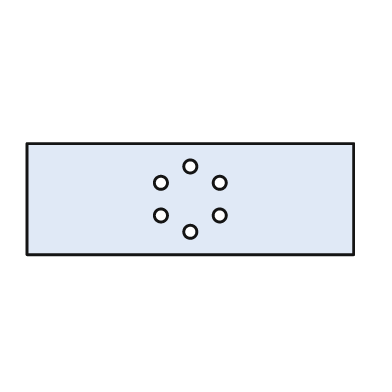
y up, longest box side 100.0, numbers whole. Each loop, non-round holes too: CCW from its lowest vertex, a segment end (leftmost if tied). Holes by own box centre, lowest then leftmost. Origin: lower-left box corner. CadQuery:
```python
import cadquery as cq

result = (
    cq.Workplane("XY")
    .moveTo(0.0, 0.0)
    .lineTo(100.0, 0.0)
    .lineTo(100.0, 34.0)
    .lineTo(0.0, 34.0)
    .close()
    .moveTo(50.0, 7.0)
    .circle(2.0)
    .moveTo(41.0, 12.0)
    .circle(2.0)
    .moveTo(59.0, 12.0)
    .circle(2.0)
    .moveTo(41.0, 22.0)
    .circle(2.0)
    .moveTo(59.0, 22.0)
    .circle(2.0)
    .moveTo(50.0, 27.0)
    .circle(2.0)
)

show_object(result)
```